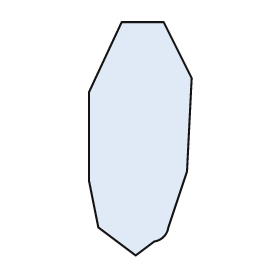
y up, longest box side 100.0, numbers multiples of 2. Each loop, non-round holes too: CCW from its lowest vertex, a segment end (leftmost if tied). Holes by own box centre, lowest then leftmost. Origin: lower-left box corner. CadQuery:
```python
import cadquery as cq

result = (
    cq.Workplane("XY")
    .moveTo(20.0, 0.0)
    .lineTo(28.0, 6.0)
    .threePointArc((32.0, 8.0), (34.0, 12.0))
    .lineTo(42.0, 36.0)
    .lineTo(44.0, 76.0)
    .lineTo(32.0, 100.0)
    .lineTo(14.0, 100.0)
    .lineTo(0.0, 70.0)
    .lineTo(0.0, 32.0)
    .lineTo(4.0, 12.0)
    .close()
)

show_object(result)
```